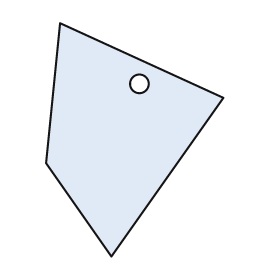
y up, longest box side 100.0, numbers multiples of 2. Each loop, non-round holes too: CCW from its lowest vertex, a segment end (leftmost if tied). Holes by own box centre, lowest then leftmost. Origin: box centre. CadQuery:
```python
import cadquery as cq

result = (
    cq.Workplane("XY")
    .moveTo(-10.0, -50.0)
    .lineTo(38.0, 18.0)
    .lineTo(-32.0, 50.0)
    .lineTo(-38.0, -10.0)
    .close()
    .moveTo(2.0, 24.0)
    .circle(4.0)
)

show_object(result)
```